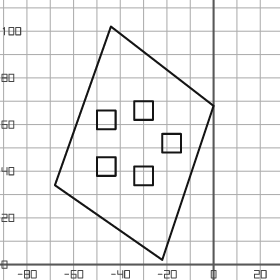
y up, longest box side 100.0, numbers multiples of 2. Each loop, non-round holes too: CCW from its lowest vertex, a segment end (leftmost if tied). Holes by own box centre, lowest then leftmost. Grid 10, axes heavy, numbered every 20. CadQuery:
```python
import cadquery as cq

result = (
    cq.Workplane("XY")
    .moveTo(-22.0, 2.0)
    .lineTo(0.0, 68.0)
    .lineTo(-44.0, 102.0)
    .lineTo(-68.0, 34.0)
    .close()
    .moveTo(-34.0, 34.0)
    .lineTo(-26.0, 34.0)
    .lineTo(-26.0, 42.0)
    .lineTo(-34.0, 42.0)
    .close()
    .moveTo(-50.0, 38.0)
    .lineTo(-42.0, 38.0)
    .lineTo(-42.0, 46.0)
    .lineTo(-50.0, 46.0)
    .close()
    .moveTo(-22.0, 48.0)
    .lineTo(-14.0, 48.0)
    .lineTo(-14.0, 56.0)
    .lineTo(-22.0, 56.0)
    .close()
    .moveTo(-50.0, 58.0)
    .lineTo(-42.0, 58.0)
    .lineTo(-42.0, 66.0)
    .lineTo(-50.0, 66.0)
    .close()
    .moveTo(-34.0, 62.0)
    .lineTo(-26.0, 62.0)
    .lineTo(-26.0, 70.0)
    .lineTo(-34.0, 70.0)
    .close()
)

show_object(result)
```